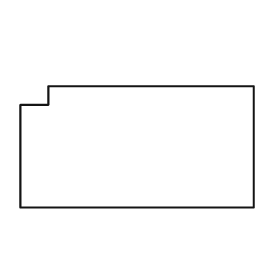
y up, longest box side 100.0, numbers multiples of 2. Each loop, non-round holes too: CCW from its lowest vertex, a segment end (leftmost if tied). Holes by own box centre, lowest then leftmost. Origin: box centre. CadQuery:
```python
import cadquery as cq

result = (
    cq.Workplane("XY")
    .moveTo(-50.0, -26.0)
    .lineTo(50.0, -26.0)
    .lineTo(50.0, 26.0)
    .lineTo(-38.0, 26.0)
    .lineTo(-38.0, 18.0)
    .lineTo(-50.0, 18.0)
    .close()
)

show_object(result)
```